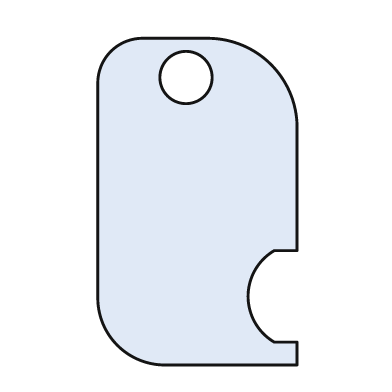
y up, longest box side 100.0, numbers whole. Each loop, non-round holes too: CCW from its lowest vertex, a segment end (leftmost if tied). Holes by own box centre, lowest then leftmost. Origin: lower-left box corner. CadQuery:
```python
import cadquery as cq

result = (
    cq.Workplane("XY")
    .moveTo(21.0, 0.0)
    .lineTo(61.0, 0.0)
    .lineTo(61.0, 7.0)
    .lineTo(54.0, 7.0)
    .threePointArc((46.0, 21.0), (54.0, 35.0))
    .lineTo(61.0, 35.0)
    .lineTo(61.0, 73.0)
    .threePointArc((53.0, 92.0), (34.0, 100.0))
    .lineTo(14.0, 100.0)
    .threePointArc((4.0, 96.0), (0.0, 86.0))
    .lineTo(0.0, 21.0)
    .threePointArc((6.0, 6.0), (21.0, 0.0))
    .close()
    .moveTo(27.0, 88.0)
    .circle(8.0)
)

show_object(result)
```